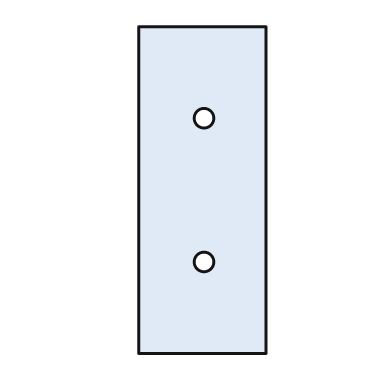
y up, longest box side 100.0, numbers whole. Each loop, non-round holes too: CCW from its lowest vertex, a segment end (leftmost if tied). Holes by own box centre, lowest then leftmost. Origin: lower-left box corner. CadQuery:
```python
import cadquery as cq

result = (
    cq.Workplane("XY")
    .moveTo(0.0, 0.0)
    .lineTo(39.0, 0.0)
    .lineTo(39.0, 100.0)
    .lineTo(0.0, 100.0)
    .close()
    .moveTo(20.0, 28.0)
    .circle(3.0)
    .moveTo(20.0, 72.0)
    .circle(3.0)
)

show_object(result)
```